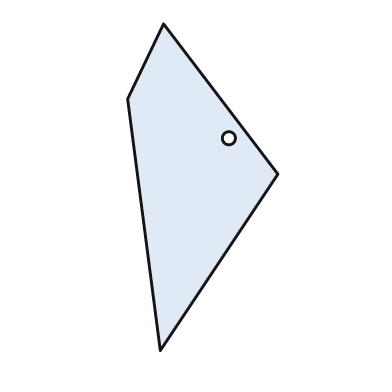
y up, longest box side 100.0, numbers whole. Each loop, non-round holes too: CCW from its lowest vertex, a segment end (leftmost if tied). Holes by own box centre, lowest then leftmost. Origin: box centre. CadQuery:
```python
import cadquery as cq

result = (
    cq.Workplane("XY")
    .moveTo(-13.0, -50.0)
    .lineTo(23.0, 4.0)
    .lineTo(-12.0, 50.0)
    .lineTo(-23.0, 27.0)
    .close()
    .moveTo(8.0, 15.0)
    .circle(2.0)
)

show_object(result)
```